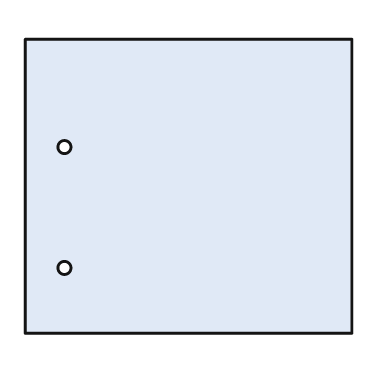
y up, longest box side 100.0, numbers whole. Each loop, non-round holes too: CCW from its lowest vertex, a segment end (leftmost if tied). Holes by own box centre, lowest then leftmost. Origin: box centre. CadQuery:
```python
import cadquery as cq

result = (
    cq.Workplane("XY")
    .moveTo(-50.0, -45.0)
    .lineTo(50.0, -45.0)
    .lineTo(50.0, 45.0)
    .lineTo(-50.0, 45.0)
    .close()
    .moveTo(-38.0, -25.0)
    .circle(2.0)
    .moveTo(-38.0, 12.0)
    .circle(2.0)
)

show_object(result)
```